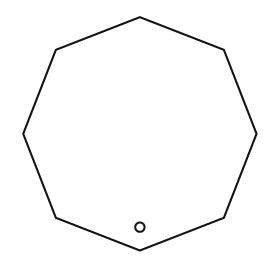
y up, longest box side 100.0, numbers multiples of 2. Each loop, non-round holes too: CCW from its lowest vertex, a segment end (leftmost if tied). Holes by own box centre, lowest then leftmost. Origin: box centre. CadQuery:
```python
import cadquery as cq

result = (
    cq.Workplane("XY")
    .moveTo(0.0, -50.0)
    .lineTo(36.0, -36.0)
    .lineTo(50.0, 0.0)
    .lineTo(36.0, 36.0)
    .lineTo(0.0, 50.0)
    .lineTo(-36.0, 36.0)
    .lineTo(-50.0, 0.0)
    .lineTo(-36.0, -36.0)
    .close()
    .moveTo(0.0, -40.0)
    .circle(2.0)
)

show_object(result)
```